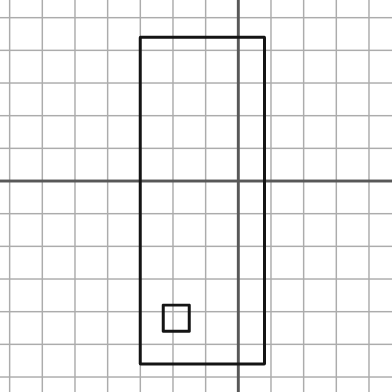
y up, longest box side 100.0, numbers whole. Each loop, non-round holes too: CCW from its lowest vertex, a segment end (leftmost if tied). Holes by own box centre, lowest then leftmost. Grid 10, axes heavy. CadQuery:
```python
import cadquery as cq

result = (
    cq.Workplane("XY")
    .moveTo(-30.0, -56.0)
    .lineTo(8.0, -56.0)
    .lineTo(8.0, 44.0)
    .lineTo(-30.0, 44.0)
    .close()
    .moveTo(-23.0, -46.0)
    .lineTo(-15.0, -46.0)
    .lineTo(-15.0, -38.0)
    .lineTo(-23.0, -38.0)
    .close()
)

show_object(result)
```